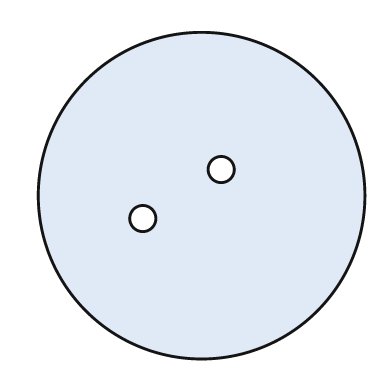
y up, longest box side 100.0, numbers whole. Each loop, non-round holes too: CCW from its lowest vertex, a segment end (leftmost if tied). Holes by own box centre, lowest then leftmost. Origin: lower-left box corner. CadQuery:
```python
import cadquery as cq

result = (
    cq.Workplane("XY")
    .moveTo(50.0, 50.0)
    .circle(50.0)
    .moveTo(32.0, 43.0)
    .circle(4.0)
    .moveTo(56.0, 58.0)
    .circle(4.0)
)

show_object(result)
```